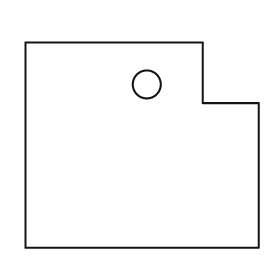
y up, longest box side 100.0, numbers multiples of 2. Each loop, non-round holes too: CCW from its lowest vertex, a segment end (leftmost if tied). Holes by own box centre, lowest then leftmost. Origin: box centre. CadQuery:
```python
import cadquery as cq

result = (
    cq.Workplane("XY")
    .moveTo(-50.0, -44.0)
    .lineTo(50.0, -44.0)
    .lineTo(50.0, 18.0)
    .lineTo(26.0, 18.0)
    .lineTo(26.0, 44.0)
    .lineTo(-50.0, 44.0)
    .close()
    .moveTo(2.0, 26.0)
    .circle(6.0)
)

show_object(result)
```